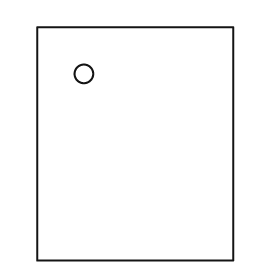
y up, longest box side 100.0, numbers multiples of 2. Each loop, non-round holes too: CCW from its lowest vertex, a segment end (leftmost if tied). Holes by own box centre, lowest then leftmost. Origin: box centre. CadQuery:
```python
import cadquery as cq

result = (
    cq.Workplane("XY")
    .moveTo(-42.0, -50.0)
    .lineTo(42.0, -50.0)
    .lineTo(42.0, 50.0)
    .lineTo(-42.0, 50.0)
    .close()
    .moveTo(-22.0, 30.0)
    .circle(4.0)
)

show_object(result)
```